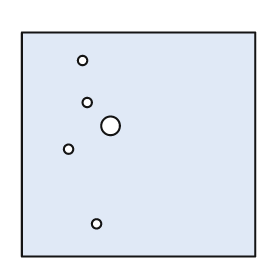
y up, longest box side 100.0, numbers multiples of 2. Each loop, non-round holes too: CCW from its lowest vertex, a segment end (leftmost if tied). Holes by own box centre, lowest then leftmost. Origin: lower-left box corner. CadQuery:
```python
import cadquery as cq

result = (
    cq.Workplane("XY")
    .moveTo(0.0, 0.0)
    .lineTo(100.0, 0.0)
    .lineTo(100.0, 96.0)
    .lineTo(0.0, 96.0)
    .close()
    .moveTo(32.0, 14.0)
    .circle(2.0)
    .moveTo(20.0, 46.0)
    .circle(2.0)
    .moveTo(38.0, 56.0)
    .circle(4.0)
    .moveTo(28.0, 66.0)
    .circle(2.0)
    .moveTo(26.0, 84.0)
    .circle(2.0)
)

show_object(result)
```